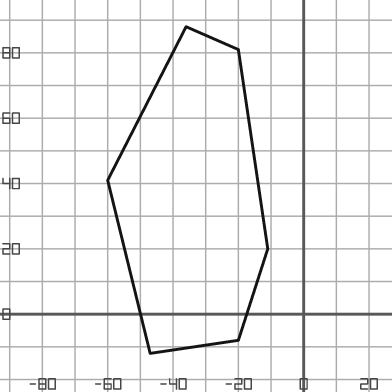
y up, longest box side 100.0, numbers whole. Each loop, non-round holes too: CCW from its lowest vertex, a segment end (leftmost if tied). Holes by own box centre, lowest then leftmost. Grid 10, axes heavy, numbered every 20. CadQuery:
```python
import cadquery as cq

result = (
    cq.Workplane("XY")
    .moveTo(-47.0, -12.0)
    .lineTo(-20.0, -8.0)
    .lineTo(-11.0, 20.0)
    .lineTo(-20.0, 81.0)
    .lineTo(-36.0, 88.0)
    .lineTo(-60.0, 41.0)
    .close()
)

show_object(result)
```